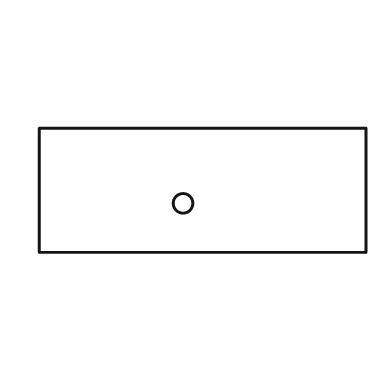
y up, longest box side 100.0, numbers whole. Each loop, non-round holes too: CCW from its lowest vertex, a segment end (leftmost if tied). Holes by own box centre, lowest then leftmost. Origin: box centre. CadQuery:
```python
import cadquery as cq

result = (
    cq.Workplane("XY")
    .moveTo(-50.0, -19.0)
    .lineTo(50.0, -19.0)
    .lineTo(50.0, 19.0)
    .lineTo(-50.0, 19.0)
    .close()
    .moveTo(-6.0, -4.0)
    .circle(3.0)
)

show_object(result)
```